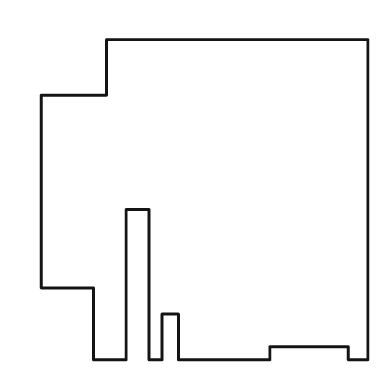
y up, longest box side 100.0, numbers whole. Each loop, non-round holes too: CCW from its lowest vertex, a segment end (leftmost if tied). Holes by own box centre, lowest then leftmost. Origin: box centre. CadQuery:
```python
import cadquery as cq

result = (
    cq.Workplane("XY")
    .moveTo(-34.0, -49.0)
    .lineTo(-24.0, -49.0)
    .lineTo(-24.0, -3.0)
    .lineTo(-17.0, -3.0)
    .lineTo(-17.0, -49.0)
    .lineTo(-13.0, -49.0)
    .lineTo(-13.0, -35.0)
    .lineTo(-8.0, -35.0)
    .lineTo(-8.0, -49.0)
    .lineTo(20.0, -49.0)
    .lineTo(20.0, -45.0)
    .lineTo(44.0, -45.0)
    .lineTo(44.0, -49.0)
    .lineTo(50.0, -49.0)
    .lineTo(50.0, 49.0)
    .lineTo(-30.0, 49.0)
    .lineTo(-30.0, 32.0)
    .lineTo(-50.0, 32.0)
    .lineTo(-50.0, -27.0)
    .lineTo(-34.0, -27.0)
    .close()
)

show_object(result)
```